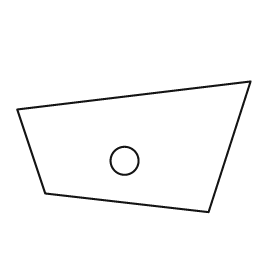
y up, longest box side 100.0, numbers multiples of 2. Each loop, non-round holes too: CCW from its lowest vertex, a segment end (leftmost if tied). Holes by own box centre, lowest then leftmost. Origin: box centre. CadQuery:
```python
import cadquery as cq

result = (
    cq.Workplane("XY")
    .moveTo(32.0, -28.0)
    .lineTo(50.0, 28.0)
    .lineTo(-50.0, 16.0)
    .lineTo(-38.0, -20.0)
    .close()
    .moveTo(-4.0, -6.0)
    .circle(6.0)
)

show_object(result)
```